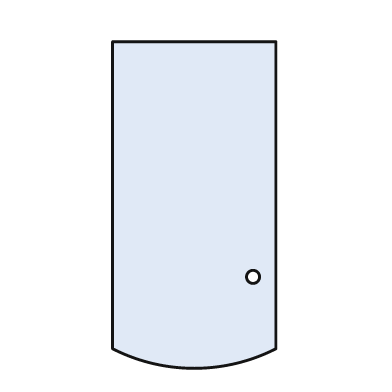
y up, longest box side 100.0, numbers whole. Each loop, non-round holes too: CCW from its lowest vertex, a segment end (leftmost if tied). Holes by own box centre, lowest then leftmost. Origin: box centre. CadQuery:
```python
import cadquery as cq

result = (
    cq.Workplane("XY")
    .moveTo(-25.0, -44.0)
    .threePointArc((0.0, -50.0), (25.0, -44.0))
    .lineTo(25.0, 50.0)
    .lineTo(-25.0, 50.0)
    .close()
    .moveTo(18.0, -22.0)
    .circle(2.0)
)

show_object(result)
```